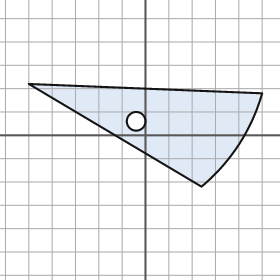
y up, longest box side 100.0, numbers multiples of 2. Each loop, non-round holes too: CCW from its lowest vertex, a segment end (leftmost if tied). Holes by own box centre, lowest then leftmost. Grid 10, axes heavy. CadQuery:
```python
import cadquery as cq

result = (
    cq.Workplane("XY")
    .moveTo(24.0, -22.0)
    .threePointArc((40.0, -4.0), (50.0, 18.0))
    .lineTo(-50.0, 22.0)
    .close()
    .moveTo(-4.0, 6.0)
    .circle(4.0)
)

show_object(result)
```